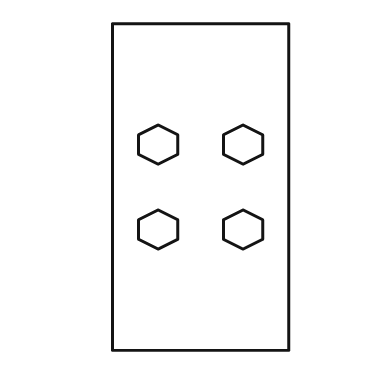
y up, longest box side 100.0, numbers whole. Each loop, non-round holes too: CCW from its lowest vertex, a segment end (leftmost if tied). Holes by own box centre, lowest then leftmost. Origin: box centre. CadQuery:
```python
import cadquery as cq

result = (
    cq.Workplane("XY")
    .moveTo(-27.0, -50.0)
    .lineTo(27.0, -50.0)
    .lineTo(27.0, 50.0)
    .lineTo(-27.0, 50.0)
    .close()
    .moveTo(-13.0, -19.0)
    .lineTo(-7.0, -16.0)
    .lineTo(-7.0, -10.0)
    .lineTo(-13.0, -7.0)
    .lineTo(-19.0, -10.0)
    .lineTo(-19.0, -16.0)
    .close()
    .moveTo(13.0, -19.0)
    .lineTo(19.0, -16.0)
    .lineTo(19.0, -10.0)
    .lineTo(13.0, -7.0)
    .lineTo(7.0, -10.0)
    .lineTo(7.0, -16.0)
    .close()
    .moveTo(-13.0, 7.0)
    .lineTo(-7.0, 10.0)
    .lineTo(-7.0, 16.0)
    .lineTo(-13.0, 19.0)
    .lineTo(-19.0, 16.0)
    .lineTo(-19.0, 10.0)
    .close()
    .moveTo(13.0, 7.0)
    .lineTo(19.0, 10.0)
    .lineTo(19.0, 16.0)
    .lineTo(13.0, 19.0)
    .lineTo(7.0, 16.0)
    .lineTo(7.0, 10.0)
    .close()
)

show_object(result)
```